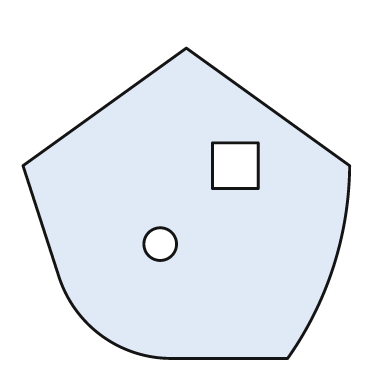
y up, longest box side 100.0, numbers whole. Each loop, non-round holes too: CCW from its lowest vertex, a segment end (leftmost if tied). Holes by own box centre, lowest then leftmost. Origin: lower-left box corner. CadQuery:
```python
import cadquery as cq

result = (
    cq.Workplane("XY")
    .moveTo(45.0, 0.0)
    .lineTo(81.0, 0.0)
    .threePointArc((95.0, 28.0), (100.0, 59.0))
    .lineTo(50.0, 95.0)
    .lineTo(0.0, 59.0)
    .lineTo(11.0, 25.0)
    .threePointArc((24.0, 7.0), (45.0, 0.0))
    .close()
    .moveTo(42.0, 35.0)
    .circle(5.0)
    .moveTo(58.0, 52.0)
    .lineTo(72.0, 52.0)
    .lineTo(72.0, 66.0)
    .lineTo(58.0, 66.0)
    .close()
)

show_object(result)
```